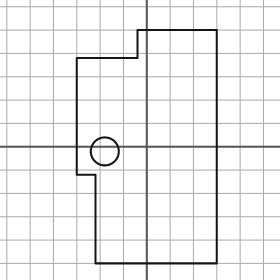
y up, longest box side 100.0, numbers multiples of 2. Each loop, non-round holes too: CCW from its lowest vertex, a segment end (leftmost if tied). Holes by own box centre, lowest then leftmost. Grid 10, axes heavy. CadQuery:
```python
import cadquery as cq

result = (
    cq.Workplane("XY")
    .moveTo(-22.0, -50.0)
    .lineTo(30.0, -50.0)
    .lineTo(30.0, 50.0)
    .lineTo(-4.0, 50.0)
    .lineTo(-4.0, 38.0)
    .lineTo(-30.0, 38.0)
    .lineTo(-30.0, -12.0)
    .lineTo(-22.0, -12.0)
    .close()
    .moveTo(-18.0, -2.0)
    .circle(6.0)
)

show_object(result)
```